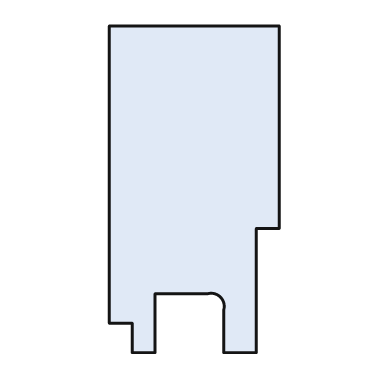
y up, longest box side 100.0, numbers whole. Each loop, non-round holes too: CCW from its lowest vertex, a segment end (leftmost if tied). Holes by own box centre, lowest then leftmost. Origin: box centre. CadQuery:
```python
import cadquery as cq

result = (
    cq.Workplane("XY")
    .moveTo(-19.0, -50.0)
    .lineTo(-12.0, -50.0)
    .lineTo(-12.0, -32.0)
    .lineTo(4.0, -32.0)
    .threePointArc((8.0, -33.0), (9.0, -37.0))
    .lineTo(9.0, -50.0)
    .lineTo(19.0, -50.0)
    .lineTo(19.0, -12.0)
    .lineTo(26.0, -12.0)
    .lineTo(26.0, 50.0)
    .lineTo(-26.0, 50.0)
    .lineTo(-26.0, -41.0)
    .lineTo(-19.0, -41.0)
    .close()
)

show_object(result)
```